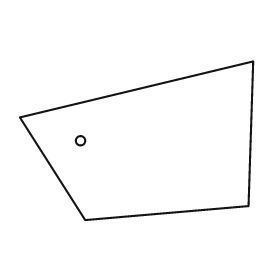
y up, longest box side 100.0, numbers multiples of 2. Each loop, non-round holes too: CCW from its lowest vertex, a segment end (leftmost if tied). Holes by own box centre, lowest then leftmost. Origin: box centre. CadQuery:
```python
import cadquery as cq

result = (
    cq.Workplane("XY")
    .moveTo(-22.0, -34.0)
    .lineTo(48.0, -28.0)
    .lineTo(50.0, 34.0)
    .lineTo(-50.0, 10.0)
    .close()
    .moveTo(-24.0, 0.0)
    .circle(2.0)
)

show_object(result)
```